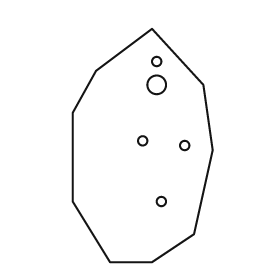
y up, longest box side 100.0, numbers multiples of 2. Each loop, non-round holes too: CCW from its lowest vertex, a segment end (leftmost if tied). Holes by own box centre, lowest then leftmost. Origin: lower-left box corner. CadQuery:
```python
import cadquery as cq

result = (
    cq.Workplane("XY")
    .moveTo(16.0, 0.0)
    .lineTo(34.0, 0.0)
    .lineTo(52.0, 12.0)
    .lineTo(60.0, 48.0)
    .lineTo(56.0, 76.0)
    .lineTo(34.0, 100.0)
    .lineTo(10.0, 82.0)
    .lineTo(0.0, 64.0)
    .lineTo(0.0, 26.0)
    .close()
    .moveTo(38.0, 26.0)
    .circle(2.0)
    .moveTo(48.0, 50.0)
    .circle(2.0)
    .moveTo(30.0, 52.0)
    .circle(2.0)
    .moveTo(36.0, 76.0)
    .circle(4.0)
    .moveTo(36.0, 86.0)
    .circle(2.0)
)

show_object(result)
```